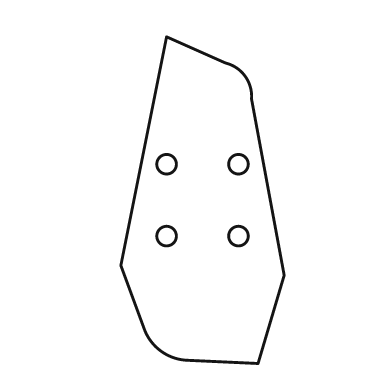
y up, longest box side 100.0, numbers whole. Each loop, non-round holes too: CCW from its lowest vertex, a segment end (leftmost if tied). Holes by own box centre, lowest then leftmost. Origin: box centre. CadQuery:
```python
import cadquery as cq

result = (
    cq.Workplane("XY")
    .moveTo(17.0, -50.0)
    .lineTo(25.0, -23.0)
    .lineTo(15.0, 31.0)
    .threePointArc((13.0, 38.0), (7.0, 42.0))
    .lineTo(-11.0, 50.0)
    .lineTo(-25.0, -20.0)
    .lineTo(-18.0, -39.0)
    .threePointArc((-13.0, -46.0), (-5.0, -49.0))
    .close()
    .moveTo(-11.0, -11.0)
    .circle(3.0)
    .moveTo(11.0, -11.0)
    .circle(3.0)
    .moveTo(-11.0, 11.0)
    .circle(3.0)
    .moveTo(11.0, 11.0)
    .circle(3.0)
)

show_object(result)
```